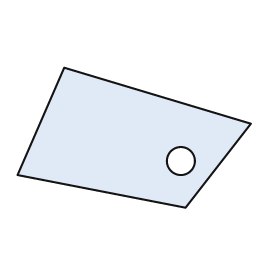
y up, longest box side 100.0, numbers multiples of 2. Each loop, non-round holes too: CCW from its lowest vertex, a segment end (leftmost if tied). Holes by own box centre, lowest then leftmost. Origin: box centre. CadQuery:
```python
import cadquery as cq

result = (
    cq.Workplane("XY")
    .moveTo(22.0, -30.0)
    .lineTo(50.0, 6.0)
    .lineTo(-30.0, 30.0)
    .lineTo(-50.0, -16.0)
    .close()
    .moveTo(20.0, -10.0)
    .circle(6.0)
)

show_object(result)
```